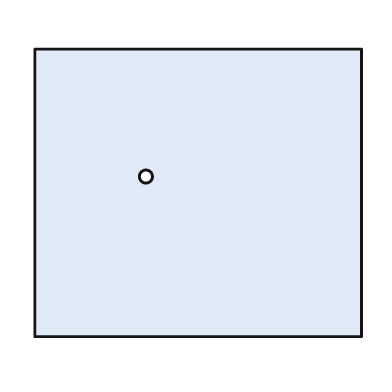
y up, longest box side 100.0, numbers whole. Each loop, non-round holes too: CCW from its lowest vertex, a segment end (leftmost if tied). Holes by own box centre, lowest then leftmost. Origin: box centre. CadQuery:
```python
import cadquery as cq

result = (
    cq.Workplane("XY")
    .moveTo(-50.0, -44.0)
    .lineTo(50.0, -44.0)
    .lineTo(50.0, 44.0)
    .lineTo(-50.0, 44.0)
    .close()
    .moveTo(-16.0, 5.0)
    .circle(2.0)
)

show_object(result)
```